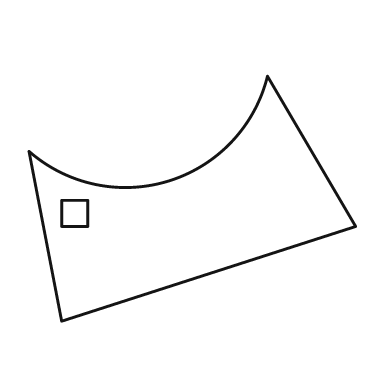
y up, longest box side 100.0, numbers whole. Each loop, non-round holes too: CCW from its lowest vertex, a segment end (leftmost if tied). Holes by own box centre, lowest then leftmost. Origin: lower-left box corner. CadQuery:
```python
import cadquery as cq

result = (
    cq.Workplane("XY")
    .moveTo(10.0, 0.0)
    .lineTo(100.0, 29.0)
    .lineTo(73.0, 75.0)
    .threePointArc((43.0, 43.0), (0.0, 52.0))
    .close()
    .moveTo(10.0, 29.0)
    .lineTo(18.0, 29.0)
    .lineTo(18.0, 37.0)
    .lineTo(10.0, 37.0)
    .close()
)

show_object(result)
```